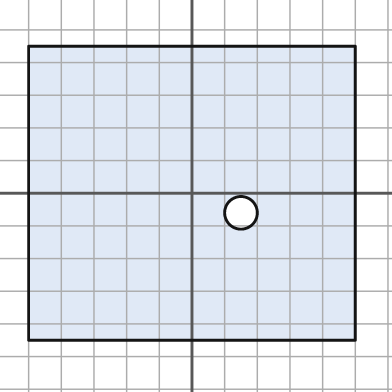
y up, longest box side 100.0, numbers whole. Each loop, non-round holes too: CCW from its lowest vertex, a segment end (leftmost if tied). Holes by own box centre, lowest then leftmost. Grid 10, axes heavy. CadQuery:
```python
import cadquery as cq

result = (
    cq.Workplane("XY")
    .moveTo(-50.0, -45.0)
    .lineTo(50.0, -45.0)
    .lineTo(50.0, 45.0)
    .lineTo(-50.0, 45.0)
    .close()
    .moveTo(15.0, -6.0)
    .circle(5.0)
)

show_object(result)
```